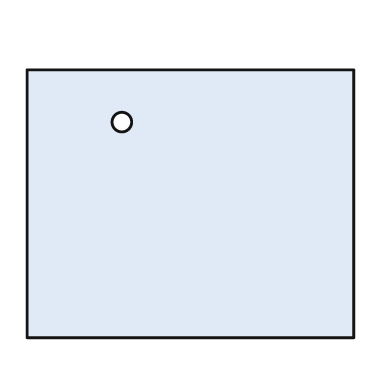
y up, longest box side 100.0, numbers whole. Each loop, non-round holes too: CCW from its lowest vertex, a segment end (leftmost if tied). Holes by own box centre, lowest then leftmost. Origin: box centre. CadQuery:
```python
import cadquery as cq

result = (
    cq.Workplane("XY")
    .moveTo(-50.0, -41.0)
    .lineTo(50.0, -41.0)
    .lineTo(50.0, 41.0)
    .lineTo(-50.0, 41.0)
    .close()
    .moveTo(-21.0, 25.0)
    .circle(3.0)
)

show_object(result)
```